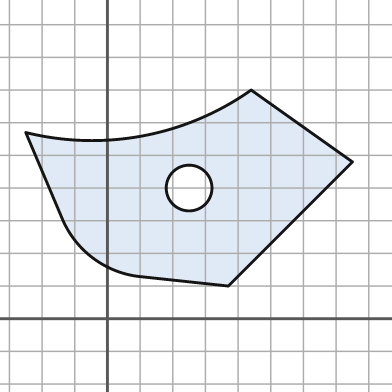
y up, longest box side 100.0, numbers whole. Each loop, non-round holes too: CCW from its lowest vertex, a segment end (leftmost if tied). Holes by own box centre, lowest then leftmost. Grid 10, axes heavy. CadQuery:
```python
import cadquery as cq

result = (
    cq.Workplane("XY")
    .moveTo(37.0, 10.0)
    .lineTo(75.0, 48.0)
    .lineTo(44.0, 70.0)
    .threePointArc((11.0, 56.0), (-25.0, 57.0))
    .lineTo(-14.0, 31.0)
    .threePointArc((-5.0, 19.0), (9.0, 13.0))
    .close()
    .moveTo(25.0, 40.0)
    .circle(7.0)
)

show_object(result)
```